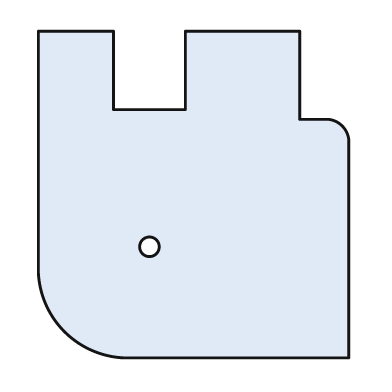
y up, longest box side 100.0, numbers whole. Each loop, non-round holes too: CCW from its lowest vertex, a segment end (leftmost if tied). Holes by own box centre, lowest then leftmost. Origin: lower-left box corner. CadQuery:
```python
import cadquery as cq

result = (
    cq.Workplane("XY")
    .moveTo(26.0, 0.0)
    .lineTo(95.0, 0.0)
    .lineTo(95.0, 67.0)
    .threePointArc((93.0, 71.0), (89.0, 73.0))
    .lineTo(80.0, 73.0)
    .lineTo(80.0, 100.0)
    .lineTo(45.0, 100.0)
    .lineTo(45.0, 76.0)
    .lineTo(23.0, 76.0)
    .lineTo(23.0, 100.0)
    .lineTo(0.0, 100.0)
    .lineTo(0.0, 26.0)
    .threePointArc((8.0, 8.0), (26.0, 0.0))
    .close()
    .moveTo(34.0, 34.0)
    .circle(3.0)
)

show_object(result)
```